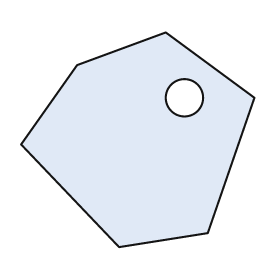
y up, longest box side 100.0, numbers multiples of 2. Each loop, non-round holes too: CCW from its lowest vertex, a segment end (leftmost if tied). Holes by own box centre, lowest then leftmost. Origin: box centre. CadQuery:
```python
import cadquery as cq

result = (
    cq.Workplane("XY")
    .moveTo(-8.0, -46.0)
    .lineTo(30.0, -40.0)
    .lineTo(50.0, 18.0)
    .lineTo(12.0, 46.0)
    .lineTo(-26.0, 32.0)
    .lineTo(-50.0, -2.0)
    .close()
    .moveTo(20.0, 18.0)
    .circle(8.0)
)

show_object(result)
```